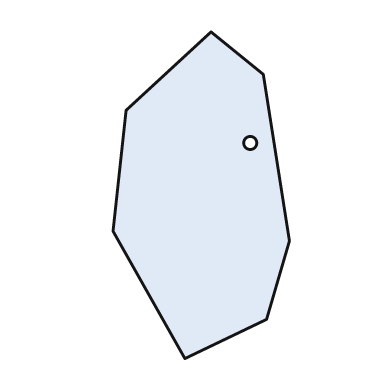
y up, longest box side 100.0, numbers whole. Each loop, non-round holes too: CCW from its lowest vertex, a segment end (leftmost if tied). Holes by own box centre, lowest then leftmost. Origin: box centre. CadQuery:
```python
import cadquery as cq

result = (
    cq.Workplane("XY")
    .moveTo(-5.0, -50.0)
    .lineTo(20.0, -38.0)
    .lineTo(27.0, -14.0)
    .lineTo(19.0, 37.0)
    .lineTo(3.0, 50.0)
    .lineTo(-23.0, 26.0)
    .lineTo(-27.0, -11.0)
    .close()
    .moveTo(15.0, 16.0)
    .circle(2.0)
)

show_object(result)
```